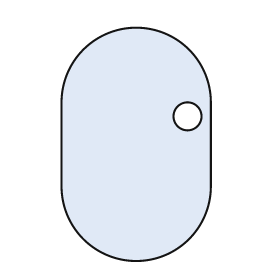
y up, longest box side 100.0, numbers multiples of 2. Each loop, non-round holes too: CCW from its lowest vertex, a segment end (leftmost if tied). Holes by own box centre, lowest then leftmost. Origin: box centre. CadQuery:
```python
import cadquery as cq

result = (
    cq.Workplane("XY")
    .moveTo(-32.0, -18.0)
    .threePointArc((0.0, -50.0), (32.0, -18.0))
    .lineTo(32.0, 18.0)
    .threePointArc((0.0, 50.0), (-32.0, 18.0))
    .close()
    .moveTo(22.0, 12.0)
    .circle(6.0)
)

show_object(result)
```